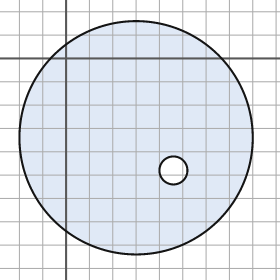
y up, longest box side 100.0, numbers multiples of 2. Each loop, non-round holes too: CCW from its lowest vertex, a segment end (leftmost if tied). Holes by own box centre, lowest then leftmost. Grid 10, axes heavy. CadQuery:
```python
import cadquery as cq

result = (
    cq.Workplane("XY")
    .moveTo(30.0, -34.0)
    .circle(50.0)
    .moveTo(46.0, -48.0)
    .circle(6.0)
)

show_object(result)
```